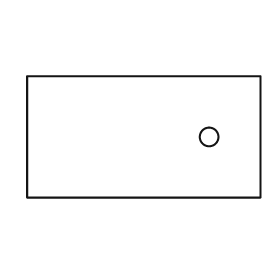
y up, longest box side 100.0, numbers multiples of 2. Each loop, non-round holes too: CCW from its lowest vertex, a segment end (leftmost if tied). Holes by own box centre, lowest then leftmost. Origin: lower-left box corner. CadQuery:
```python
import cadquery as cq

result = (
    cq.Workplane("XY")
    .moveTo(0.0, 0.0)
    .lineTo(100.0, 0.0)
    .lineTo(100.0, 52.0)
    .lineTo(0.0, 52.0)
    .close()
    .moveTo(78.0, 26.0)
    .circle(4.0)
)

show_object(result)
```